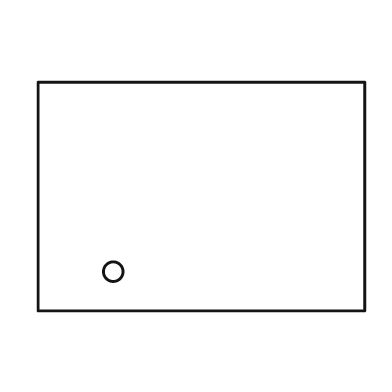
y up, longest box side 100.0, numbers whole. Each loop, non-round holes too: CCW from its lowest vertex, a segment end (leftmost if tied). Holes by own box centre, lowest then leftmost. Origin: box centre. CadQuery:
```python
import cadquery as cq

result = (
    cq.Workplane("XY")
    .moveTo(-50.0, -35.0)
    .lineTo(50.0, -35.0)
    .lineTo(50.0, 35.0)
    .lineTo(-50.0, 35.0)
    .close()
    .moveTo(-27.0, -23.0)
    .circle(3.0)
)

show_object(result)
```